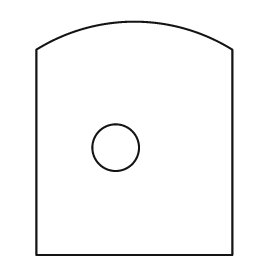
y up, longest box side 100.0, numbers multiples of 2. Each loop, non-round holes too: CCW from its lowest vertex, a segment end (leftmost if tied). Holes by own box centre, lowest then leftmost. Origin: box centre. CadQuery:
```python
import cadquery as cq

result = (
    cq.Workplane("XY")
    .moveTo(-42.0, -50.0)
    .lineTo(42.0, -50.0)
    .lineTo(42.0, 38.0)
    .threePointArc((0.0, 50.0), (-42.0, 38.0))
    .close()
    .moveTo(-8.0, -4.0)
    .circle(10.0)
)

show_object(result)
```